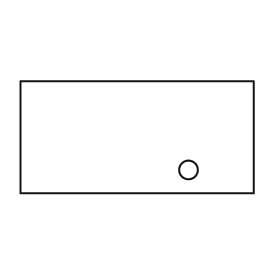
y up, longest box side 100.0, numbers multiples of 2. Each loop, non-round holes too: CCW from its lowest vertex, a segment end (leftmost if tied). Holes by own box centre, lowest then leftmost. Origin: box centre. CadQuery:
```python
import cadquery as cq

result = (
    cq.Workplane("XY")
    .moveTo(-50.0, -24.0)
    .lineTo(50.0, -24.0)
    .lineTo(50.0, 24.0)
    .lineTo(-50.0, 24.0)
    .close()
    .moveTo(22.0, -14.0)
    .circle(4.0)
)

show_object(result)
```